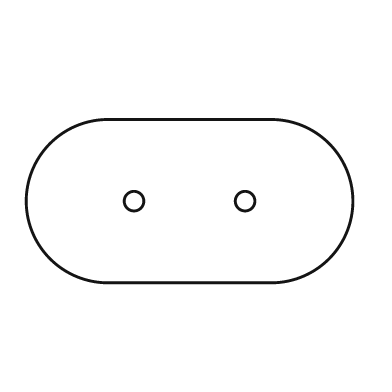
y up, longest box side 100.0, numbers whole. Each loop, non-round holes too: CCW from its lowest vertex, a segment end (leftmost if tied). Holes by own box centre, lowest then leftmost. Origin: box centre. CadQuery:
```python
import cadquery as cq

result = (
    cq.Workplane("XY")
    .moveTo(-25.0, -25.0)
    .lineTo(25.0, -25.0)
    .threePointArc((50.0, 0.0), (25.0, 25.0))
    .lineTo(-25.0, 25.0)
    .threePointArc((-50.0, 0.0), (-25.0, -25.0))
    .close()
    .moveTo(-17.0, 0.0)
    .circle(3.0)
    .moveTo(17.0, 0.0)
    .circle(3.0)
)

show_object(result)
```